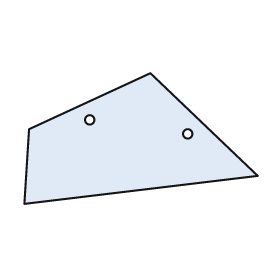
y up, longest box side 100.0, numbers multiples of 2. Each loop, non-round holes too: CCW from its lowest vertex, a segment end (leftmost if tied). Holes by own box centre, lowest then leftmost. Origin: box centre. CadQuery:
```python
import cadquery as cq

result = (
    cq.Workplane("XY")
    .moveTo(-50.0, -28.0)
    .lineTo(50.0, -16.0)
    .lineTo(4.0, 28.0)
    .lineTo(-48.0, 4.0)
    .close()
    .moveTo(20.0, 2.0)
    .circle(2.0)
    .moveTo(-22.0, 8.0)
    .circle(2.0)
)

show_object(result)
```